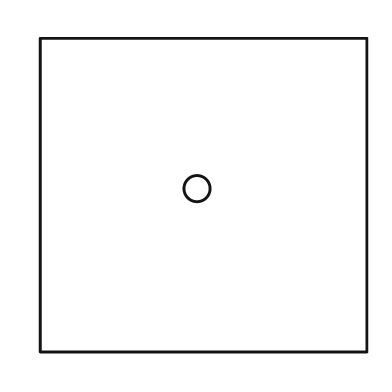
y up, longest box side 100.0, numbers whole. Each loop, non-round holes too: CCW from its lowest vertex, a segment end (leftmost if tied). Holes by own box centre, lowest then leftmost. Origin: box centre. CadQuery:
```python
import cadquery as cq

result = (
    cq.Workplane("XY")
    .moveTo(-50.0, -48.0)
    .lineTo(50.0, -48.0)
    .lineTo(50.0, 48.0)
    .lineTo(-50.0, 48.0)
    .close()
    .moveTo(-2.0, 2.0)
    .circle(4.0)
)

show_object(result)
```